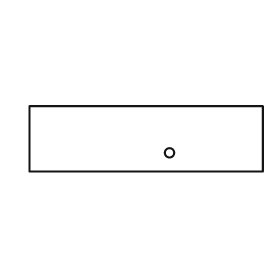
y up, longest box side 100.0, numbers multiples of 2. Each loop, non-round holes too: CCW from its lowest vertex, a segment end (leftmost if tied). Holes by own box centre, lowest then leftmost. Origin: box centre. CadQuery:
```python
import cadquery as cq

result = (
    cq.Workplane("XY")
    .moveTo(-50.0, -14.0)
    .lineTo(50.0, -14.0)
    .lineTo(50.0, 14.0)
    .lineTo(-50.0, 14.0)
    .close()
    .moveTo(10.0, -6.0)
    .circle(2.0)
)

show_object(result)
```